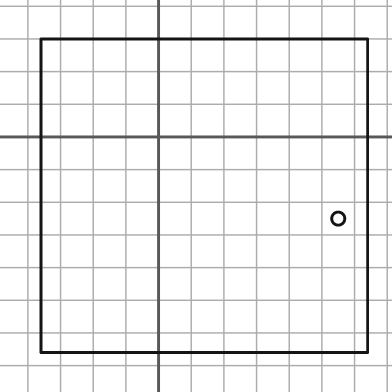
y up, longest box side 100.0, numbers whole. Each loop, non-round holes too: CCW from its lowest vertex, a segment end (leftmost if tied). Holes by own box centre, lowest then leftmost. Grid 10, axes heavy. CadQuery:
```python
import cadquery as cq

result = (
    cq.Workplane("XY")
    .moveTo(-36.0, -66.0)
    .lineTo(64.0, -66.0)
    .lineTo(64.0, 30.0)
    .lineTo(-36.0, 30.0)
    .close()
    .moveTo(55.0, -25.0)
    .circle(2.0)
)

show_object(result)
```